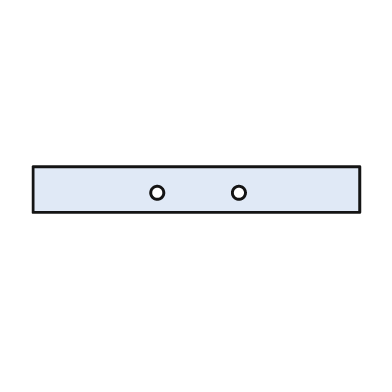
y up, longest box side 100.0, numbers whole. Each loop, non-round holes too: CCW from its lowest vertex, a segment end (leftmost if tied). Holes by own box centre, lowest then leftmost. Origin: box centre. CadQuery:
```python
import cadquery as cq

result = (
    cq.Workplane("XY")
    .moveTo(-50.0, -7.0)
    .lineTo(50.0, -7.0)
    .lineTo(50.0, 7.0)
    .lineTo(-50.0, 7.0)
    .close()
    .moveTo(-12.0, -1.0)
    .circle(2.0)
    .moveTo(13.0, -1.0)
    .circle(2.0)
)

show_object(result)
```